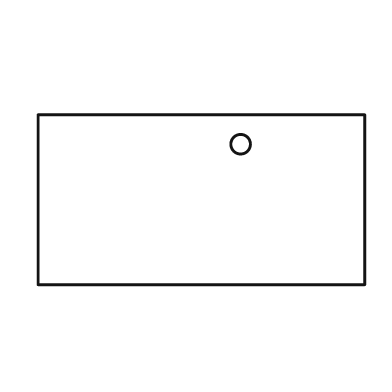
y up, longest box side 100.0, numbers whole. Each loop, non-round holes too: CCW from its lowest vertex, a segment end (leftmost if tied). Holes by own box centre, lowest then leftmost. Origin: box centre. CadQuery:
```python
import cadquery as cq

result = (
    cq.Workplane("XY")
    .moveTo(-50.0, -26.0)
    .lineTo(50.0, -26.0)
    .lineTo(50.0, 26.0)
    .lineTo(-50.0, 26.0)
    .close()
    .moveTo(12.0, 17.0)
    .circle(3.0)
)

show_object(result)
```